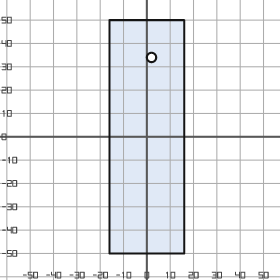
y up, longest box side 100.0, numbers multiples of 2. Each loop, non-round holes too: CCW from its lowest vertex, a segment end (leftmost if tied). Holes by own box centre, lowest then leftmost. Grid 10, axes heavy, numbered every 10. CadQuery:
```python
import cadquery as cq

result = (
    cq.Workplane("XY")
    .moveTo(-16.0, -50.0)
    .lineTo(16.0, -50.0)
    .lineTo(16.0, 50.0)
    .lineTo(-16.0, 50.0)
    .close()
    .moveTo(2.0, 34.0)
    .circle(2.0)
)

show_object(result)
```